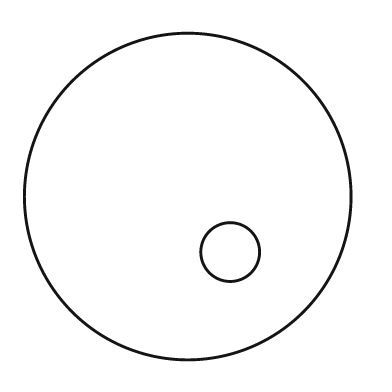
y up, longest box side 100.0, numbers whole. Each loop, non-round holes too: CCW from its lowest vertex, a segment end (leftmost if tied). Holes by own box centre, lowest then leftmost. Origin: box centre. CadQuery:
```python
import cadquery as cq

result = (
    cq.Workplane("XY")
    .moveTo(0.0, 0.0)
    .circle(50.0)
    .moveTo(13.0, -17.0)
    .circle(9.0)
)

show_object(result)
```